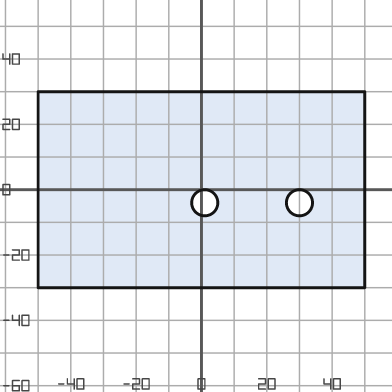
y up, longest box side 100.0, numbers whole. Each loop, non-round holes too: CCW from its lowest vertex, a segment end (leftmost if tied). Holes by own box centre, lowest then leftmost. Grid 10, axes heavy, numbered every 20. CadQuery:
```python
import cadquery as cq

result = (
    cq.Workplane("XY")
    .moveTo(-50.0, -30.0)
    .lineTo(50.0, -30.0)
    .lineTo(50.0, 30.0)
    .lineTo(-50.0, 30.0)
    .close()
    .moveTo(1.0, -4.0)
    .circle(4.0)
    .moveTo(30.0, -4.0)
    .circle(4.0)
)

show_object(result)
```